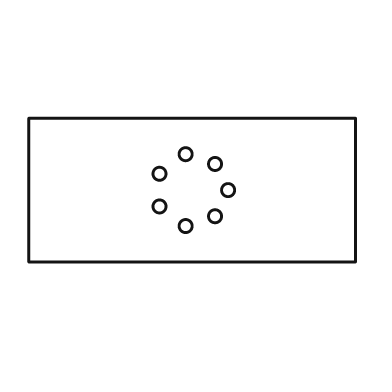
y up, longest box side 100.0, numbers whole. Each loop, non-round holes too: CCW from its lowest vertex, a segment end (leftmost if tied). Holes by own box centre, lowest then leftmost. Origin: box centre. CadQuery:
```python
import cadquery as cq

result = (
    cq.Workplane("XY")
    .moveTo(-50.0, -22.0)
    .lineTo(50.0, -22.0)
    .lineTo(50.0, 22.0)
    .lineTo(-50.0, 22.0)
    .close()
    .moveTo(-2.0, -11.0)
    .circle(2.0)
    .moveTo(7.0, -8.0)
    .circle(2.0)
    .moveTo(-10.0, -5.0)
    .circle(2.0)
    .moveTo(11.0, 0.0)
    .circle(2.0)
    .moveTo(-10.0, 5.0)
    .circle(2.0)
    .moveTo(7.0, 8.0)
    .circle(2.0)
    .moveTo(-2.0, 11.0)
    .circle(2.0)
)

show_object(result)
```